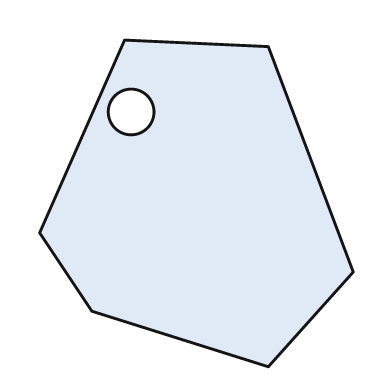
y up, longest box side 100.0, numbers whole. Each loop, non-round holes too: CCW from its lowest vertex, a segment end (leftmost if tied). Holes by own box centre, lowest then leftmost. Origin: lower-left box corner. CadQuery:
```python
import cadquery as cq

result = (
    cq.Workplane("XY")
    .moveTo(70.0, 0.0)
    .lineTo(96.0, 29.0)
    .lineTo(70.0, 98.0)
    .lineTo(26.0, 100.0)
    .lineTo(0.0, 41.0)
    .lineTo(16.0, 17.0)
    .close()
    .moveTo(28.0, 78.0)
    .circle(7.0)
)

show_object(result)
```